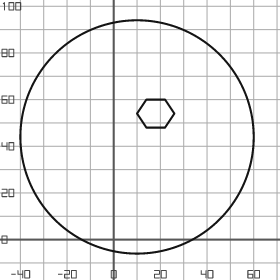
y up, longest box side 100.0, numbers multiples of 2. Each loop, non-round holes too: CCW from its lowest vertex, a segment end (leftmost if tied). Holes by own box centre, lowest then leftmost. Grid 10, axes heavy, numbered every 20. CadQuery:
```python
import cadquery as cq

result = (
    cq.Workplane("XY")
    .moveTo(10.0, 44.0)
    .circle(50.0)
    .moveTo(14.0, 48.0)
    .lineTo(22.0, 48.0)
    .lineTo(26.0, 54.0)
    .lineTo(22.0, 60.0)
    .lineTo(14.0, 60.0)
    .lineTo(10.0, 54.0)
    .close()
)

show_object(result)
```